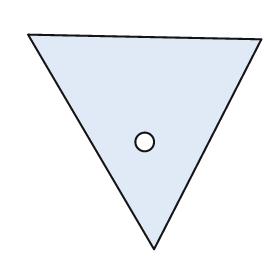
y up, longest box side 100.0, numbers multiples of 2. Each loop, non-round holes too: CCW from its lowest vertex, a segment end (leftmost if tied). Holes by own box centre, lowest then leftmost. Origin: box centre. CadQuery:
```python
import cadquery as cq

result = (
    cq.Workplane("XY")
    .moveTo(4.0, -46.0)
    .lineTo(50.0, 44.0)
    .lineTo(-50.0, 46.0)
    .close()
    .moveTo(0.0, 0.0)
    .circle(4.0)
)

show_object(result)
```